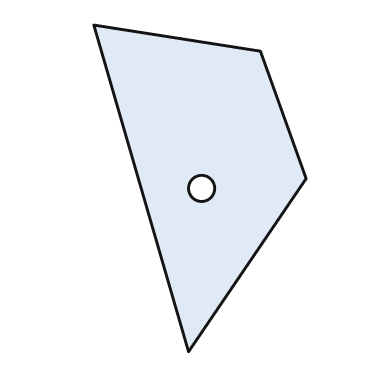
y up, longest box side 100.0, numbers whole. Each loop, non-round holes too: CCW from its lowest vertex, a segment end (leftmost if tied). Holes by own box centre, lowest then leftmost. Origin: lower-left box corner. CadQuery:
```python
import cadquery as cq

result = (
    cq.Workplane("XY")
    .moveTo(29.0, 0.0)
    .lineTo(65.0, 53.0)
    .lineTo(51.0, 92.0)
    .lineTo(0.0, 100.0)
    .close()
    .moveTo(33.0, 50.0)
    .circle(4.0)
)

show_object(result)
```